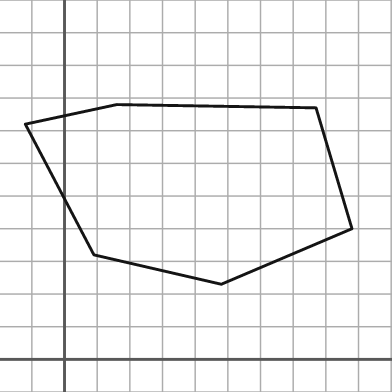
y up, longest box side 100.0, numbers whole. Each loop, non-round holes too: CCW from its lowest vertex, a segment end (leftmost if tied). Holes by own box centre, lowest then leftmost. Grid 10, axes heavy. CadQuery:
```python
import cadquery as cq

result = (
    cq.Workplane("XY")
    .moveTo(48.0, 23.0)
    .lineTo(88.0, 40.0)
    .lineTo(77.0, 77.0)
    .lineTo(16.0, 78.0)
    .lineTo(-12.0, 72.0)
    .lineTo(9.0, 32.0)
    .close()
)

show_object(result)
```